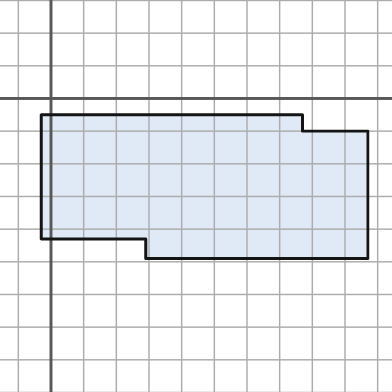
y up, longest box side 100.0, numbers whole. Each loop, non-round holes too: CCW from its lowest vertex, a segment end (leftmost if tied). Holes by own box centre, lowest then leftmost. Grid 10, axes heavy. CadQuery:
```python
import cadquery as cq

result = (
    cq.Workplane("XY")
    .moveTo(29.0, -49.0)
    .lineTo(97.0, -49.0)
    .lineTo(97.0, -10.0)
    .lineTo(77.0, -10.0)
    .lineTo(77.0, -5.0)
    .lineTo(-3.0, -5.0)
    .lineTo(-3.0, -43.0)
    .lineTo(29.0, -43.0)
    .close()
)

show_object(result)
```